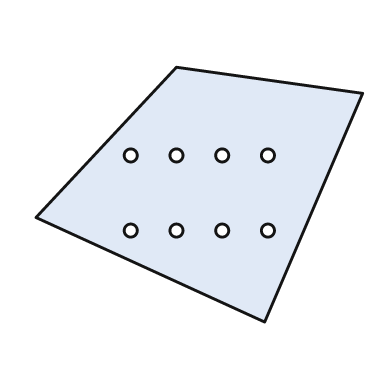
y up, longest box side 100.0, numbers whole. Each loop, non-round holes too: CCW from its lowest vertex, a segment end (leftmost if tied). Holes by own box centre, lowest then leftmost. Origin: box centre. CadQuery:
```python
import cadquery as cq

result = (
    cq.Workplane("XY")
    .moveTo(20.0, -39.0)
    .lineTo(50.0, 31.0)
    .lineTo(-7.0, 39.0)
    .lineTo(-50.0, -7.0)
    .close()
    .moveTo(-21.0, -11.0)
    .circle(2.0)
    .moveTo(-7.0, -11.0)
    .circle(2.0)
    .moveTo(7.0, -11.0)
    .circle(2.0)
    .moveTo(21.0, -11.0)
    .circle(2.0)
    .moveTo(-21.0, 12.0)
    .circle(2.0)
    .moveTo(-7.0, 12.0)
    .circle(2.0)
    .moveTo(7.0, 12.0)
    .circle(2.0)
    .moveTo(21.0, 12.0)
    .circle(2.0)
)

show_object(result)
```